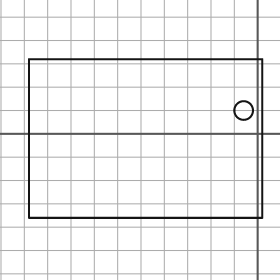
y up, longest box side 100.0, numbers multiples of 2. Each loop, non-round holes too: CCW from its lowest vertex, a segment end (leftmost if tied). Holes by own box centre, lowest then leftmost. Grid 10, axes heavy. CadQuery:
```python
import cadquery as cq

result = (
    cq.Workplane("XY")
    .moveTo(-98.0, -36.0)
    .lineTo(2.0, -36.0)
    .lineTo(2.0, 32.0)
    .lineTo(-98.0, 32.0)
    .close()
    .moveTo(-6.0, 10.0)
    .circle(4.0)
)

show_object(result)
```